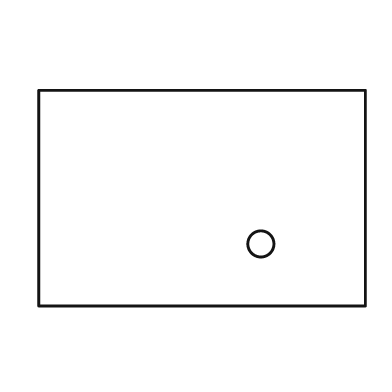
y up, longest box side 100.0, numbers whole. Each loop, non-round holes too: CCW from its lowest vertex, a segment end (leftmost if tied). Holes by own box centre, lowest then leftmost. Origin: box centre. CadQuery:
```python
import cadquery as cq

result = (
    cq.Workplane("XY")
    .moveTo(-50.0, -33.0)
    .lineTo(50.0, -33.0)
    .lineTo(50.0, 33.0)
    .lineTo(-50.0, 33.0)
    .close()
    .moveTo(18.0, -14.0)
    .circle(4.0)
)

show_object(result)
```